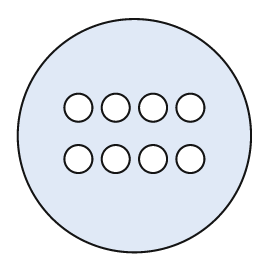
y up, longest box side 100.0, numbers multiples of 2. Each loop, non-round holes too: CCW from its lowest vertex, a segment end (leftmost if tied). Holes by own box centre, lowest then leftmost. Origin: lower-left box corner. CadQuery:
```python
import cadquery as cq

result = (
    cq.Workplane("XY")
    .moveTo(50.0, 50.0)
    .circle(50.0)
    .moveTo(26.0, 40.0)
    .circle(6.0)
    .moveTo(42.0, 40.0)
    .circle(6.0)
    .moveTo(58.0, 40.0)
    .circle(6.0)
    .moveTo(74.0, 40.0)
    .circle(6.0)
    .moveTo(26.0, 62.0)
    .circle(6.0)
    .moveTo(42.0, 62.0)
    .circle(6.0)
    .moveTo(58.0, 62.0)
    .circle(6.0)
    .moveTo(74.0, 62.0)
    .circle(6.0)
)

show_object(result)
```